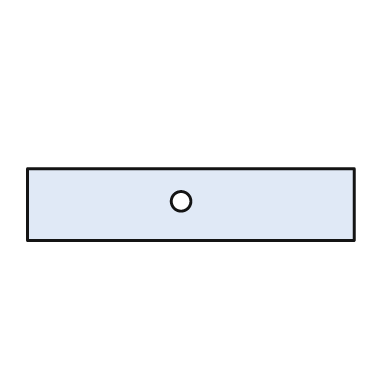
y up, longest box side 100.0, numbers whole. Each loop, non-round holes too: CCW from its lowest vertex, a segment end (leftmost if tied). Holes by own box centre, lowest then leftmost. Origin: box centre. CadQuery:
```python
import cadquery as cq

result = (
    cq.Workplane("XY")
    .moveTo(-50.0, -11.0)
    .lineTo(50.0, -11.0)
    .lineTo(50.0, 11.0)
    .lineTo(-50.0, 11.0)
    .close()
    .moveTo(-3.0, 1.0)
    .circle(3.0)
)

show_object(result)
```